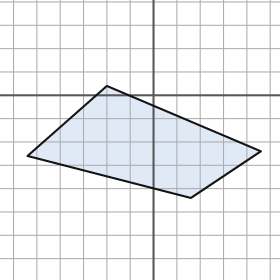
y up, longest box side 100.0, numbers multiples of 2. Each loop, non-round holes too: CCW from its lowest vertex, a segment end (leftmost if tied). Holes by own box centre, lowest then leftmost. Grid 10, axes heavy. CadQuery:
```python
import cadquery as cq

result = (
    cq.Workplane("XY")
    .moveTo(16.0, -44.0)
    .lineTo(46.0, -24.0)
    .lineTo(-20.0, 4.0)
    .lineTo(-54.0, -26.0)
    .close()
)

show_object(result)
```